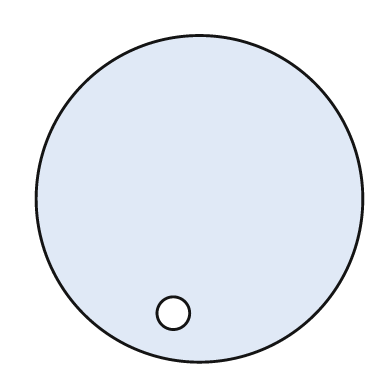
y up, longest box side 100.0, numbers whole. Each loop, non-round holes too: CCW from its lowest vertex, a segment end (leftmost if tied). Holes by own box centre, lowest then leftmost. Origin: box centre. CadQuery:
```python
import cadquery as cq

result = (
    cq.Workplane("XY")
    .moveTo(0.0, 0.0)
    .circle(50.0)
    .moveTo(-8.0, -35.0)
    .circle(5.0)
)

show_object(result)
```